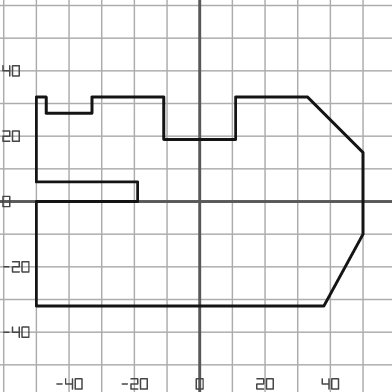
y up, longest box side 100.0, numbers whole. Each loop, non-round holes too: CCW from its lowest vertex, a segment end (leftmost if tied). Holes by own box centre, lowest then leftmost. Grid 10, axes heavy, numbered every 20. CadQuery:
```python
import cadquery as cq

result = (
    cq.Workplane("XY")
    .moveTo(-50.0, -32.0)
    .lineTo(38.0, -32.0)
    .lineTo(50.0, -10.0)
    .lineTo(50.0, 15.0)
    .lineTo(33.0, 32.0)
    .lineTo(11.0, 32.0)
    .lineTo(11.0, 19.0)
    .lineTo(-11.0, 19.0)
    .lineTo(-11.0, 32.0)
    .lineTo(-33.0, 32.0)
    .lineTo(-33.0, 27.0)
    .lineTo(-47.0, 27.0)
    .lineTo(-47.0, 32.0)
    .lineTo(-50.0, 32.0)
    .lineTo(-50.0, 6.0)
    .lineTo(-19.0, 6.0)
    .lineTo(-19.0, 0.0)
    .lineTo(-50.0, 0.0)
    .close()
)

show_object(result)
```